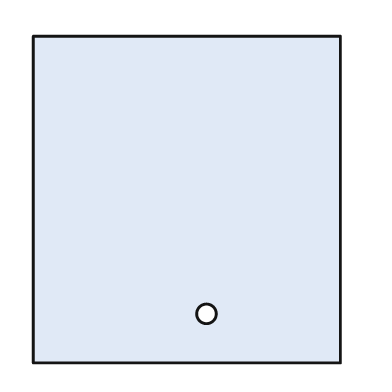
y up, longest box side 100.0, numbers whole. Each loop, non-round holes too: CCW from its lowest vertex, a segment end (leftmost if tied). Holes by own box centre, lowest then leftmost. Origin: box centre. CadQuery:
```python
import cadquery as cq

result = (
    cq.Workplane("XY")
    .moveTo(-47.0, -50.0)
    .lineTo(47.0, -50.0)
    .lineTo(47.0, 50.0)
    .lineTo(-47.0, 50.0)
    .close()
    .moveTo(6.0, -35.0)
    .circle(3.0)
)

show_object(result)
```